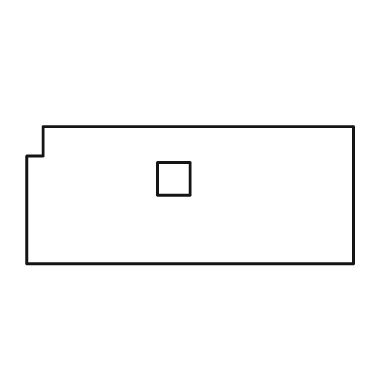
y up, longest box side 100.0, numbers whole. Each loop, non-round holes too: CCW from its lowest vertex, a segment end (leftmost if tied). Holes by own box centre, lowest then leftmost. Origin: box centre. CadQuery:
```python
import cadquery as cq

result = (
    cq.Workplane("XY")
    .moveTo(-50.0, -21.0)
    .lineTo(50.0, -21.0)
    .lineTo(50.0, 21.0)
    .lineTo(-45.0, 21.0)
    .lineTo(-45.0, 12.0)
    .lineTo(-50.0, 12.0)
    .close()
    .moveTo(-10.0, 0.0)
    .lineTo(0.0, 0.0)
    .lineTo(0.0, 10.0)
    .lineTo(-10.0, 10.0)
    .close()
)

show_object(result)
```